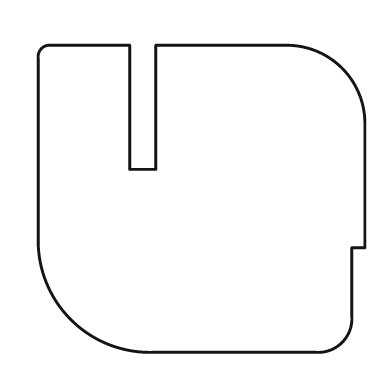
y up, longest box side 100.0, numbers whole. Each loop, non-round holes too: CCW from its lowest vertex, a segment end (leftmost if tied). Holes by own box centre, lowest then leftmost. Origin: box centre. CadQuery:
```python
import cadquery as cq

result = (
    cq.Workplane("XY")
    .moveTo(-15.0, -47.0)
    .lineTo(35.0, -47.0)
    .threePointArc((43.0, -44.0), (46.0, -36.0))
    .lineTo(46.0, -15.0)
    .lineTo(50.0, -15.0)
    .lineTo(50.0, 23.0)
    .threePointArc((43.0, 40.0), (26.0, 47.0))
    .lineTo(-14.0, 47.0)
    .lineTo(-14.0, 9.0)
    .lineTo(-22.0, 9.0)
    .lineTo(-22.0, 47.0)
    .lineTo(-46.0, 47.0)
    .threePointArc((-49.0, 46.0), (-50.0, 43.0))
    .lineTo(-50.0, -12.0)
    .threePointArc((-40.0, -37.0), (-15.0, -47.0))
    .close()
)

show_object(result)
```